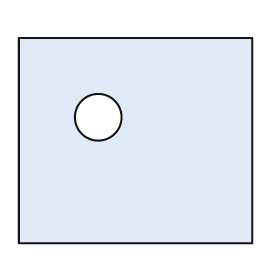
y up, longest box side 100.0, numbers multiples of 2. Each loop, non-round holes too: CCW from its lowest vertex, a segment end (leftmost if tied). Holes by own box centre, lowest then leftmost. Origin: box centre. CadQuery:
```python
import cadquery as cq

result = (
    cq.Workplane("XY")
    .moveTo(-50.0, -44.0)
    .lineTo(50.0, -44.0)
    .lineTo(50.0, 44.0)
    .lineTo(-50.0, 44.0)
    .close()
    .moveTo(-16.0, 10.0)
    .circle(10.0)
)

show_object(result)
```